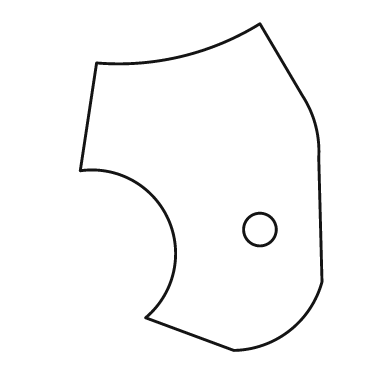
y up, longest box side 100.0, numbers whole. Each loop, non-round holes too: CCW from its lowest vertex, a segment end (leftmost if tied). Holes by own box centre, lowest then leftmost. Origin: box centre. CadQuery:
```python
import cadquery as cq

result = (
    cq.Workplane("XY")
    .moveTo(10.0, -50.0)
    .threePointArc((27.0, -44.0), (37.0, -29.0))
    .lineTo(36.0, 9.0)
    .threePointArc((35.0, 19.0), (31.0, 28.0))
    .lineTo(18.0, 50.0)
    .threePointArc((-6.0, 40.0), (-32.0, 38.0))
    .lineTo(-37.0, 5.0)
    .threePointArc((-10.0, -10.0), (-17.0, -40.0))
    .close()
    .moveTo(18.0, -13.0)
    .circle(5.0)
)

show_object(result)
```